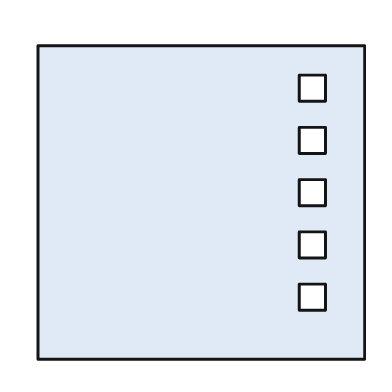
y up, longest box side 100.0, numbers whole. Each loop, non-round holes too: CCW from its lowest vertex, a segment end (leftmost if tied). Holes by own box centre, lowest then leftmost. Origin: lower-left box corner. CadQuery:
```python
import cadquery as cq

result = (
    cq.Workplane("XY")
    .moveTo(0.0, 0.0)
    .lineTo(100.0, 0.0)
    .lineTo(100.0, 96.0)
    .lineTo(0.0, 96.0)
    .close()
    .moveTo(80.0, 15.0)
    .lineTo(88.0, 15.0)
    .lineTo(88.0, 23.0)
    .lineTo(80.0, 23.0)
    .close()
    .moveTo(80.0, 31.0)
    .lineTo(88.0, 31.0)
    .lineTo(88.0, 39.0)
    .lineTo(80.0, 39.0)
    .close()
    .moveTo(80.0, 47.0)
    .lineTo(88.0, 47.0)
    .lineTo(88.0, 55.0)
    .lineTo(80.0, 55.0)
    .close()
    .moveTo(80.0, 63.0)
    .lineTo(88.0, 63.0)
    .lineTo(88.0, 71.0)
    .lineTo(80.0, 71.0)
    .close()
    .moveTo(80.0, 79.0)
    .lineTo(88.0, 79.0)
    .lineTo(88.0, 87.0)
    .lineTo(80.0, 87.0)
    .close()
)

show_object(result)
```